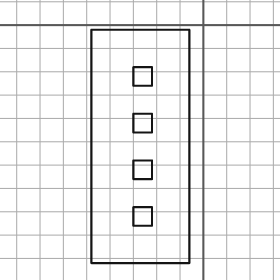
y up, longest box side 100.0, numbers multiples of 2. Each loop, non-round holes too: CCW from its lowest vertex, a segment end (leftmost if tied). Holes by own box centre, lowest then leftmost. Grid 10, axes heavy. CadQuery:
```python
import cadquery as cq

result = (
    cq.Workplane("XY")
    .moveTo(-48.0, -102.0)
    .lineTo(-6.0, -102.0)
    .lineTo(-6.0, -2.0)
    .lineTo(-48.0, -2.0)
    .close()
    .moveTo(-30.0, -86.0)
    .lineTo(-22.0, -86.0)
    .lineTo(-22.0, -78.0)
    .lineTo(-30.0, -78.0)
    .close()
    .moveTo(-30.0, -66.0)
    .lineTo(-22.0, -66.0)
    .lineTo(-22.0, -58.0)
    .lineTo(-30.0, -58.0)
    .close()
    .moveTo(-30.0, -46.0)
    .lineTo(-22.0, -46.0)
    .lineTo(-22.0, -38.0)
    .lineTo(-30.0, -38.0)
    .close()
    .moveTo(-30.0, -26.0)
    .lineTo(-22.0, -26.0)
    .lineTo(-22.0, -18.0)
    .lineTo(-30.0, -18.0)
    .close()
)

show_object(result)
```